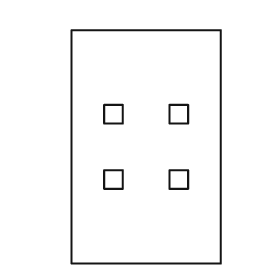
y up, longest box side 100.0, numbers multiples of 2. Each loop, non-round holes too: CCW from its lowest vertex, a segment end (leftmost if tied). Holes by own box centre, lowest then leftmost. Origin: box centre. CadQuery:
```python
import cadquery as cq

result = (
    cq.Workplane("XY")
    .moveTo(-32.0, -50.0)
    .lineTo(32.0, -50.0)
    .lineTo(32.0, 50.0)
    .lineTo(-32.0, 50.0)
    .close()
    .moveTo(-18.0, -18.0)
    .lineTo(-10.0, -18.0)
    .lineTo(-10.0, -10.0)
    .lineTo(-18.0, -10.0)
    .close()
    .moveTo(10.0, -18.0)
    .lineTo(18.0, -18.0)
    .lineTo(18.0, -10.0)
    .lineTo(10.0, -10.0)
    .close()
    .moveTo(-18.0, 10.0)
    .lineTo(-10.0, 10.0)
    .lineTo(-10.0, 18.0)
    .lineTo(-18.0, 18.0)
    .close()
    .moveTo(10.0, 10.0)
    .lineTo(18.0, 10.0)
    .lineTo(18.0, 18.0)
    .lineTo(10.0, 18.0)
    .close()
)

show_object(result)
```